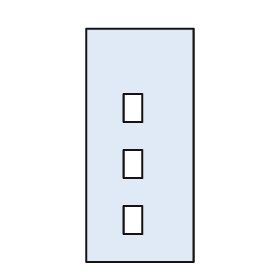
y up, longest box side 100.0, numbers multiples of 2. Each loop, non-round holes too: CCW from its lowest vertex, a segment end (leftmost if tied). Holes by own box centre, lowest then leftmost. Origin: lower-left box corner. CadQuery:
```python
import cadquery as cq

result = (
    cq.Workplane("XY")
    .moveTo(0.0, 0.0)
    .lineTo(46.0, 0.0)
    .lineTo(46.0, 100.0)
    .lineTo(0.0, 100.0)
    .close()
    .moveTo(16.0, 12.0)
    .lineTo(24.0, 12.0)
    .lineTo(24.0, 24.0)
    .lineTo(16.0, 24.0)
    .close()
    .moveTo(16.0, 36.0)
    .lineTo(24.0, 36.0)
    .lineTo(24.0, 48.0)
    .lineTo(16.0, 48.0)
    .close()
    .moveTo(16.0, 60.0)
    .lineTo(24.0, 60.0)
    .lineTo(24.0, 72.0)
    .lineTo(16.0, 72.0)
    .close()
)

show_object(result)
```